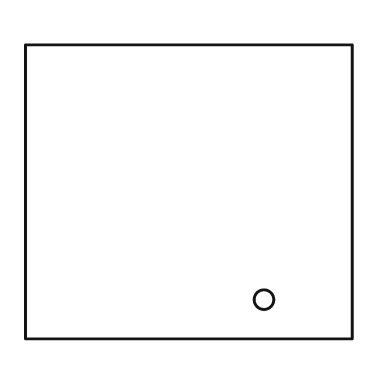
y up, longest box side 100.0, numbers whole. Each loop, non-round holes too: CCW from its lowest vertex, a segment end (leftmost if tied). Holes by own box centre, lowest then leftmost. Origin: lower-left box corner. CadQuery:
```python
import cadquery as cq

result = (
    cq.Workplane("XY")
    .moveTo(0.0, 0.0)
    .lineTo(100.0, 0.0)
    .lineTo(100.0, 90.0)
    .lineTo(0.0, 90.0)
    .close()
    .moveTo(73.0, 12.0)
    .circle(3.0)
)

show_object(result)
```